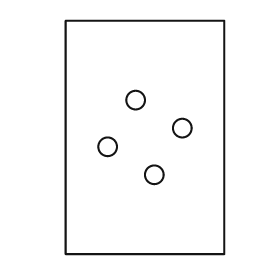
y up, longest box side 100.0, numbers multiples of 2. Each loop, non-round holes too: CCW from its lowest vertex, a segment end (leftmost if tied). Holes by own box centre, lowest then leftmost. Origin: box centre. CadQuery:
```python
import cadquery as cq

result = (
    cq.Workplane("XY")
    .moveTo(-34.0, -50.0)
    .lineTo(34.0, -50.0)
    .lineTo(34.0, 50.0)
    .lineTo(-34.0, 50.0)
    .close()
    .moveTo(4.0, -16.0)
    .circle(4.0)
    .moveTo(-16.0, -4.0)
    .circle(4.0)
    .moveTo(16.0, 4.0)
    .circle(4.0)
    .moveTo(-4.0, 16.0)
    .circle(4.0)
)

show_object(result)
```